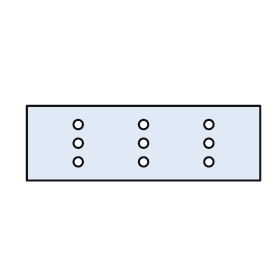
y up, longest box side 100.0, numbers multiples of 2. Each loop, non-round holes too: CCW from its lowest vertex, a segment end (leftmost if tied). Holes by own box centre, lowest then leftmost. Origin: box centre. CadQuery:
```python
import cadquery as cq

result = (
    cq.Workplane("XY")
    .moveTo(-50.0, -16.0)
    .lineTo(50.0, -16.0)
    .lineTo(50.0, 16.0)
    .lineTo(-50.0, 16.0)
    .close()
    .moveTo(-28.0, -8.0)
    .circle(2.0)
    .moveTo(0.0, -8.0)
    .circle(2.0)
    .moveTo(28.0, -8.0)
    .circle(2.0)
    .moveTo(-28.0, 0.0)
    .circle(2.0)
    .moveTo(0.0, 0.0)
    .circle(2.0)
    .moveTo(28.0, 0.0)
    .circle(2.0)
    .moveTo(-28.0, 8.0)
    .circle(2.0)
    .moveTo(0.0, 8.0)
    .circle(2.0)
    .moveTo(28.0, 8.0)
    .circle(2.0)
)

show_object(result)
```